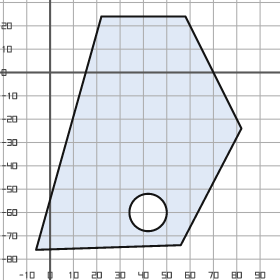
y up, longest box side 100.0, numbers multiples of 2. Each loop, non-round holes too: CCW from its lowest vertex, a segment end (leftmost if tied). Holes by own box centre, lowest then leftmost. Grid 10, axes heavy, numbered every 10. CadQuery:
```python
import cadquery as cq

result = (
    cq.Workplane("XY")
    .moveTo(-6.0, -76.0)
    .lineTo(56.0, -74.0)
    .lineTo(82.0, -24.0)
    .lineTo(58.0, 24.0)
    .lineTo(22.0, 24.0)
    .close()
    .moveTo(42.0, -60.0)
    .circle(8.0)
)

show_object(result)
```